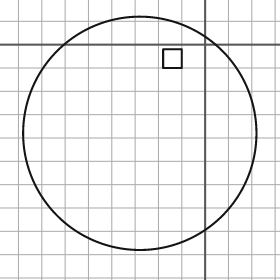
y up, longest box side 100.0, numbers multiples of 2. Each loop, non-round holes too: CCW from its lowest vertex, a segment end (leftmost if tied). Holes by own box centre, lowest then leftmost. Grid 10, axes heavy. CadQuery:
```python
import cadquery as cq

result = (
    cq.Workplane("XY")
    .moveTo(-28.0, -38.0)
    .circle(50.0)
    .moveTo(-18.0, -10.0)
    .lineTo(-10.0, -10.0)
    .lineTo(-10.0, -2.0)
    .lineTo(-18.0, -2.0)
    .close()
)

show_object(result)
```